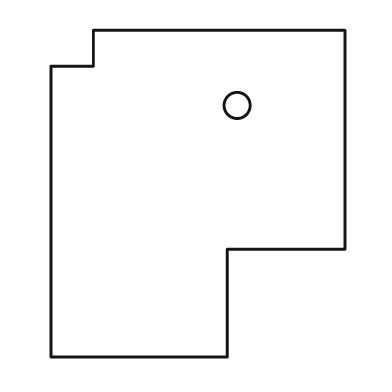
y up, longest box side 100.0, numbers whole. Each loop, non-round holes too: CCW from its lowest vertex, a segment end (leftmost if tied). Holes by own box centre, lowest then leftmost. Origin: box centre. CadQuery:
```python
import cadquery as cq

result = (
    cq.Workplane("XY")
    .moveTo(-45.0, -50.0)
    .lineTo(9.0, -50.0)
    .lineTo(9.0, -17.0)
    .lineTo(45.0, -17.0)
    .lineTo(45.0, 50.0)
    .lineTo(-32.0, 50.0)
    .lineTo(-32.0, 39.0)
    .lineTo(-45.0, 39.0)
    .close()
    .moveTo(12.0, 27.0)
    .circle(4.0)
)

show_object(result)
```